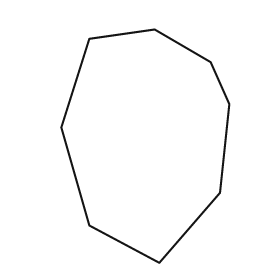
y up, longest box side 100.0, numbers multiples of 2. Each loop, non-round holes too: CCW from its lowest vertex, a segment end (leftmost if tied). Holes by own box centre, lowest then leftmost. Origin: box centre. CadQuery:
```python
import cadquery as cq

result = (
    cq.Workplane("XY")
    .moveTo(6.0, -50.0)
    .lineTo(32.0, -20.0)
    .lineTo(36.0, 18.0)
    .lineTo(28.0, 36.0)
    .lineTo(4.0, 50.0)
    .lineTo(-24.0, 46.0)
    .lineTo(-36.0, 8.0)
    .lineTo(-24.0, -34.0)
    .close()
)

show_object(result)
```